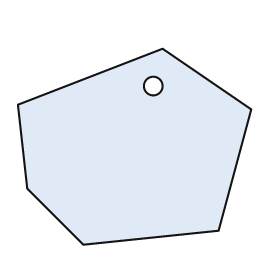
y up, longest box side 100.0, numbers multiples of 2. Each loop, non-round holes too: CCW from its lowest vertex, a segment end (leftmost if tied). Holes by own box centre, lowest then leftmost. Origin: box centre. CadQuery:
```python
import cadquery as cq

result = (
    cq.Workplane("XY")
    .moveTo(-22.0, -42.0)
    .lineTo(36.0, -36.0)
    .lineTo(50.0, 16.0)
    .lineTo(12.0, 42.0)
    .lineTo(-50.0, 18.0)
    .lineTo(-46.0, -18.0)
    .close()
    .moveTo(8.0, 26.0)
    .circle(4.0)
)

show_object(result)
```